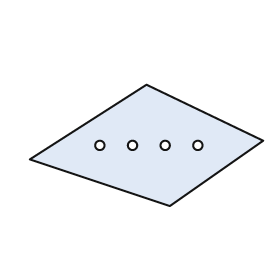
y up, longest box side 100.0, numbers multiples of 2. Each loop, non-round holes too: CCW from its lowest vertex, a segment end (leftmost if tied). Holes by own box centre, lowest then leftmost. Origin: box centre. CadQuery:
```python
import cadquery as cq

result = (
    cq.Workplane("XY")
    .moveTo(10.0, -26.0)
    .lineTo(50.0, 2.0)
    .lineTo(0.0, 26.0)
    .lineTo(-50.0, -6.0)
    .close()
    .moveTo(-20.0, 0.0)
    .circle(2.0)
    .moveTo(-6.0, 0.0)
    .circle(2.0)
    .moveTo(8.0, 0.0)
    .circle(2.0)
    .moveTo(22.0, 0.0)
    .circle(2.0)
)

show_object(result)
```